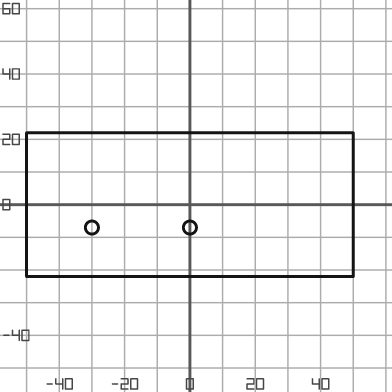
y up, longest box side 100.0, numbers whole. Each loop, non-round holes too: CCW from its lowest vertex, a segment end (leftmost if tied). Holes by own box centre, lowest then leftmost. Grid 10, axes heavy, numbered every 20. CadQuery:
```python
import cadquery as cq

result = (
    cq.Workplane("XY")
    .moveTo(-50.0, -22.0)
    .lineTo(50.0, -22.0)
    .lineTo(50.0, 22.0)
    .lineTo(-50.0, 22.0)
    .close()
    .moveTo(-30.0, -7.0)
    .circle(2.0)
    .moveTo(0.0, -7.0)
    .circle(2.0)
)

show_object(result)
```